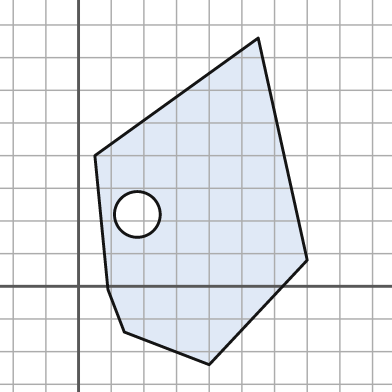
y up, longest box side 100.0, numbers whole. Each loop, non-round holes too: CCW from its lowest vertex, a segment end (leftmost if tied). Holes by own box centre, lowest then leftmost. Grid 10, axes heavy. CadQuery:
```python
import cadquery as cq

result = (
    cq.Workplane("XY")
    .moveTo(40.0, -24.0)
    .lineTo(70.0, 8.0)
    .lineTo(55.0, 76.0)
    .lineTo(5.0, 40.0)
    .lineTo(9.0, -1.0)
    .lineTo(14.0, -14.0)
    .close()
    .moveTo(18.0, 22.0)
    .circle(7.0)
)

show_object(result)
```